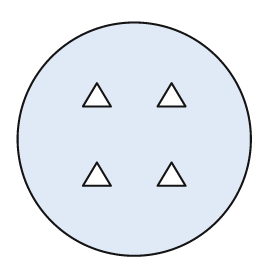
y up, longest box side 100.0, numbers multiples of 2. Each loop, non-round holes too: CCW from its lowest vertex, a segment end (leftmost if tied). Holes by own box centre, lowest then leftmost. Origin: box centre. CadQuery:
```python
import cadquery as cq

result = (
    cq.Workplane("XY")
    .moveTo(0.0, 0.0)
    .circle(50.0)
    .moveTo(-22.0, -20.0)
    .lineTo(-10.0, -20.0)
    .lineTo(-16.0, -10.0)
    .close()
    .moveTo(10.0, -20.0)
    .lineTo(22.0, -20.0)
    .lineTo(16.0, -10.0)
    .close()
    .moveTo(-22.0, 14.0)
    .lineTo(-10.0, 14.0)
    .lineTo(-16.0, 24.0)
    .close()
    .moveTo(10.0, 14.0)
    .lineTo(22.0, 14.0)
    .lineTo(16.0, 24.0)
    .close()
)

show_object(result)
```